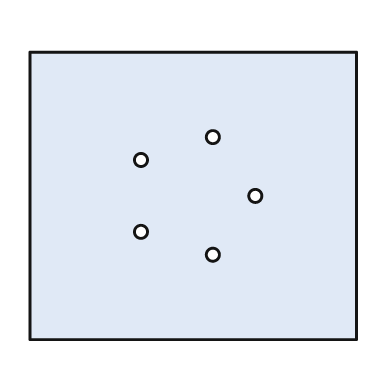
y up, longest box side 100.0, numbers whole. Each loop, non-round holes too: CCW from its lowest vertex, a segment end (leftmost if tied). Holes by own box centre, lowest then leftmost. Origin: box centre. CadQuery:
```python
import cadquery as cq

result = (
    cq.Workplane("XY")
    .moveTo(-50.0, -44.0)
    .lineTo(50.0, -44.0)
    .lineTo(50.0, 44.0)
    .lineTo(-50.0, 44.0)
    .close()
    .moveTo(6.0, -18.0)
    .circle(2.0)
    .moveTo(-16.0, -11.0)
    .circle(2.0)
    .moveTo(19.0, 0.0)
    .circle(2.0)
    .moveTo(-16.0, 11.0)
    .circle(2.0)
    .moveTo(6.0, 18.0)
    .circle(2.0)
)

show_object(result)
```